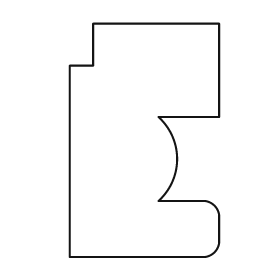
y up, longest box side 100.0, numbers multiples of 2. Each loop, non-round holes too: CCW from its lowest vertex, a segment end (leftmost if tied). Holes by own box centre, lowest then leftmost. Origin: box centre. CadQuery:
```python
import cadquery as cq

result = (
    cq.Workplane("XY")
    .moveTo(-32.0, -50.0)
    .lineTo(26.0, -50.0)
    .threePointArc((30.0, -48.0), (32.0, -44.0))
    .lineTo(32.0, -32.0)
    .threePointArc((30.0, -28.0), (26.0, -26.0))
    .lineTo(6.0, -26.0)
    .threePointArc((14.0, -8.0), (6.0, 10.0))
    .lineTo(32.0, 10.0)
    .lineTo(32.0, 50.0)
    .lineTo(-22.0, 50.0)
    .lineTo(-22.0, 32.0)
    .lineTo(-32.0, 32.0)
    .close()
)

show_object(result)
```